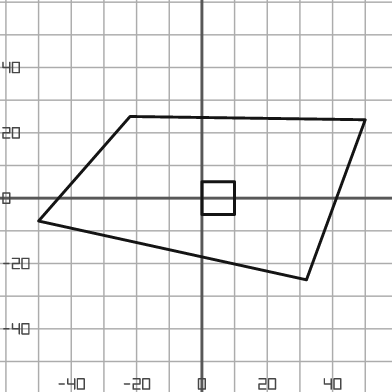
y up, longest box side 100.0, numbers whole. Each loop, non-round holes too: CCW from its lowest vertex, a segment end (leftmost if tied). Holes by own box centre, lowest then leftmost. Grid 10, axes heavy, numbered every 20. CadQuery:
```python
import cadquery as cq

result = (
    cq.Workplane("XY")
    .moveTo(32.0, -25.0)
    .lineTo(50.0, 24.0)
    .lineTo(-22.0, 25.0)
    .lineTo(-50.0, -7.0)
    .close()
    .moveTo(0.0, -5.0)
    .lineTo(10.0, -5.0)
    .lineTo(10.0, 5.0)
    .lineTo(0.0, 5.0)
    .close()
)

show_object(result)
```